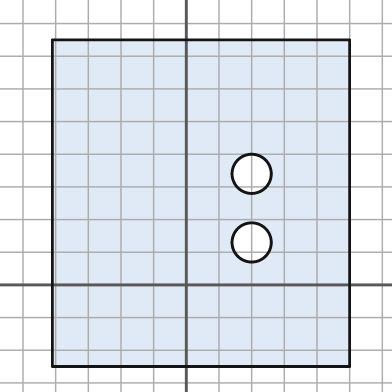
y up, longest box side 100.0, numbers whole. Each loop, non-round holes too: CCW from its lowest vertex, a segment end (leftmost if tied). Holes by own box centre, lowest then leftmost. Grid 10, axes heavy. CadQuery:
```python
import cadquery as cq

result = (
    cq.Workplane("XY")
    .moveTo(-41.0, -25.0)
    .lineTo(50.0, -25.0)
    .lineTo(50.0, 75.0)
    .lineTo(-41.0, 75.0)
    .close()
    .moveTo(20.0, 13.0)
    .circle(6.0)
    .moveTo(20.0, 34.0)
    .circle(6.0)
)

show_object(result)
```